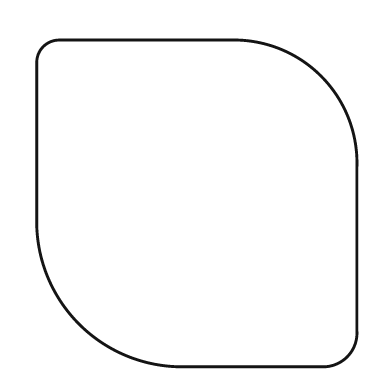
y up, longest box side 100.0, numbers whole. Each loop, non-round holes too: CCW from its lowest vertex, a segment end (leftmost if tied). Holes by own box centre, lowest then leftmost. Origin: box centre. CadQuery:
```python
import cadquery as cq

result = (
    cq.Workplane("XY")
    .moveTo(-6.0, -50.0)
    .lineTo(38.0, -50.0)
    .threePointArc((46.0, -47.0), (49.0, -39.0))
    .lineTo(49.0, 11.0)
    .threePointArc((38.0, 39.0), (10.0, 50.0))
    .lineTo(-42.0, 50.0)
    .threePointArc((-47.0, 48.0), (-49.0, 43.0))
    .lineTo(-49.0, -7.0)
    .threePointArc((-36.0, -37.0), (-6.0, -50.0))
    .close()
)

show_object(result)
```